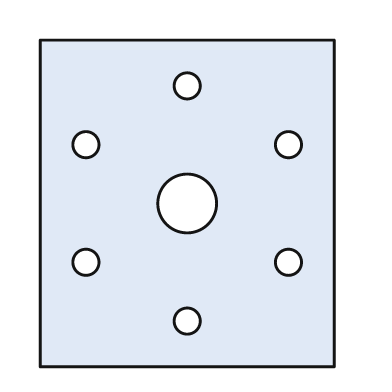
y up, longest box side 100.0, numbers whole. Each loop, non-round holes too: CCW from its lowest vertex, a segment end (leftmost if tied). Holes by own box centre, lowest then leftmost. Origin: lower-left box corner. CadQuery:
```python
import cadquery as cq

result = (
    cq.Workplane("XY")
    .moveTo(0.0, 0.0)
    .lineTo(90.0, 0.0)
    .lineTo(90.0, 100.0)
    .lineTo(0.0, 100.0)
    .close()
    .moveTo(45.0, 14.0)
    .circle(4.0)
    .moveTo(14.0, 32.0)
    .circle(4.0)
    .moveTo(76.0, 32.0)
    .circle(4.0)
    .moveTo(45.0, 50.0)
    .circle(9.0)
    .moveTo(14.0, 68.0)
    .circle(4.0)
    .moveTo(76.0, 68.0)
    .circle(4.0)
    .moveTo(45.0, 86.0)
    .circle(4.0)
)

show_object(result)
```